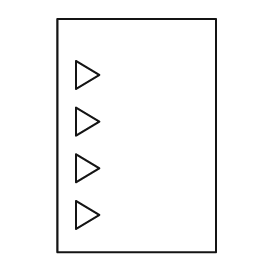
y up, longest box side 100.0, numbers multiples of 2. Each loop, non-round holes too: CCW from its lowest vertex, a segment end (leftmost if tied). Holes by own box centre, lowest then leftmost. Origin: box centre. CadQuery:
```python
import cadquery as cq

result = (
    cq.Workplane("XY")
    .moveTo(-34.0, -50.0)
    .lineTo(34.0, -50.0)
    .lineTo(34.0, 50.0)
    .lineTo(-34.0, 50.0)
    .close()
    .moveTo(-26.0, -40.0)
    .lineTo(-16.0, -34.0)
    .lineTo(-26.0, -28.0)
    .close()
    .moveTo(-26.0, -20.0)
    .lineTo(-16.0, -14.0)
    .lineTo(-26.0, -8.0)
    .close()
    .moveTo(-26.0, 0.0)
    .lineTo(-16.0, 6.0)
    .lineTo(-26.0, 12.0)
    .close()
    .moveTo(-26.0, 20.0)
    .lineTo(-16.0, 26.0)
    .lineTo(-26.0, 32.0)
    .close()
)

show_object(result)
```